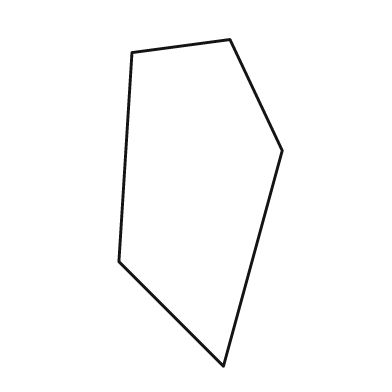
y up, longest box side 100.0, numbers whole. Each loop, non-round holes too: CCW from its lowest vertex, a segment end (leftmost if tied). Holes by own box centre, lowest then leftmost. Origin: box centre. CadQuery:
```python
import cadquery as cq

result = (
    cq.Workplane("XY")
    .moveTo(7.0, -50.0)
    .lineTo(25.0, 16.0)
    .lineTo(9.0, 50.0)
    .lineTo(-21.0, 46.0)
    .lineTo(-25.0, -18.0)
    .close()
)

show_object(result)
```